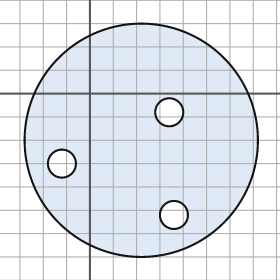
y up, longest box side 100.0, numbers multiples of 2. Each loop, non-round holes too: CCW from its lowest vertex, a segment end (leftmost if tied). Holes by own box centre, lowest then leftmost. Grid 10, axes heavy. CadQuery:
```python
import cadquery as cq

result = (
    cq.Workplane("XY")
    .moveTo(22.0, -20.0)
    .circle(50.0)
    .moveTo(36.0, -52.0)
    .circle(6.0)
    .moveTo(-12.0, -30.0)
    .circle(6.0)
    .moveTo(34.0, -8.0)
    .circle(6.0)
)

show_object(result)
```